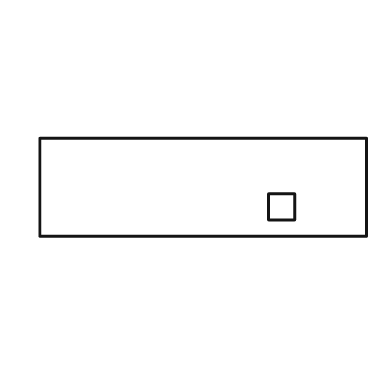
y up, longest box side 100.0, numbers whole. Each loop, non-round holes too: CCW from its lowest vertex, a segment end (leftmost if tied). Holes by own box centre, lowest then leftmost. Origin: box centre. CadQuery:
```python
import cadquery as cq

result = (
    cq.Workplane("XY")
    .moveTo(-50.0, -15.0)
    .lineTo(50.0, -15.0)
    .lineTo(50.0, 15.0)
    .lineTo(-50.0, 15.0)
    .close()
    .moveTo(20.0, -10.0)
    .lineTo(28.0, -10.0)
    .lineTo(28.0, -2.0)
    .lineTo(20.0, -2.0)
    .close()
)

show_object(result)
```